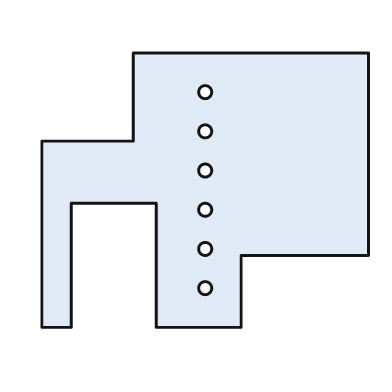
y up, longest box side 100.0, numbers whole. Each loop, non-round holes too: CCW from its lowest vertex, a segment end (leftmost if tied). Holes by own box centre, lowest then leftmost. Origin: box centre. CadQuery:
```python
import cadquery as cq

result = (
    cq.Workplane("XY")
    .moveTo(-50.0, -42.0)
    .lineTo(-41.0, -42.0)
    .lineTo(-41.0, -4.0)
    .lineTo(-15.0, -4.0)
    .lineTo(-15.0, -42.0)
    .lineTo(11.0, -42.0)
    .lineTo(11.0, -20.0)
    .lineTo(50.0, -20.0)
    .lineTo(50.0, 42.0)
    .lineTo(-22.0, 42.0)
    .lineTo(-22.0, 15.0)
    .lineTo(-50.0, 15.0)
    .close()
    .moveTo(0.0, -30.0)
    .circle(2.0)
    .moveTo(0.0, -18.0)
    .circle(2.0)
    .moveTo(0.0, -6.0)
    .circle(2.0)
    .moveTo(0.0, 6.0)
    .circle(2.0)
    .moveTo(0.0, 18.0)
    .circle(2.0)
    .moveTo(0.0, 30.0)
    .circle(2.0)
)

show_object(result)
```